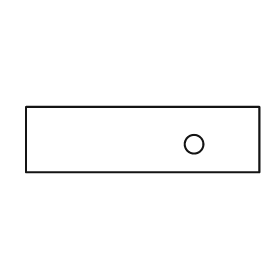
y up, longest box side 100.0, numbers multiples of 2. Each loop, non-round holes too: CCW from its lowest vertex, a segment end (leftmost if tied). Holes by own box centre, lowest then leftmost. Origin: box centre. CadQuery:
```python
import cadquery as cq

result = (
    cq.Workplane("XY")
    .moveTo(-50.0, -14.0)
    .lineTo(50.0, -14.0)
    .lineTo(50.0, 14.0)
    .lineTo(-50.0, 14.0)
    .close()
    .moveTo(22.0, -2.0)
    .circle(4.0)
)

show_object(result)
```